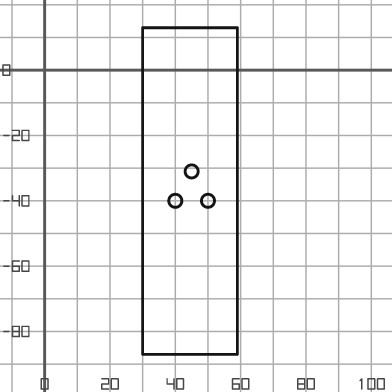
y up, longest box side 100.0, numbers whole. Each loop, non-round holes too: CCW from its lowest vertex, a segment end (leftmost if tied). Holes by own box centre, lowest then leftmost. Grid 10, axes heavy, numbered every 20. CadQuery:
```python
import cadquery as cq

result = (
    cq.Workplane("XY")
    .moveTo(30.0, -87.0)
    .lineTo(59.0, -87.0)
    .lineTo(59.0, 13.0)
    .lineTo(30.0, 13.0)
    .close()
    .moveTo(40.0, -40.0)
    .circle(2.0)
    .moveTo(50.0, -40.0)
    .circle(2.0)
    .moveTo(45.0, -31.0)
    .circle(2.0)
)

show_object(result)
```